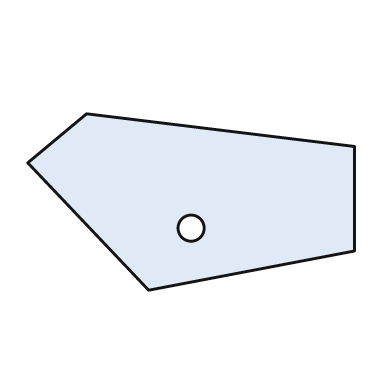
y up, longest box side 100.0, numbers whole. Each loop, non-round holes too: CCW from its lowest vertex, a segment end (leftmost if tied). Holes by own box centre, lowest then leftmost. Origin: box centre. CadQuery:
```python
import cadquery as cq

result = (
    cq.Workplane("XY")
    .moveTo(-13.0, -27.0)
    .lineTo(50.0, -15.0)
    .lineTo(50.0, 17.0)
    .lineTo(-32.0, 27.0)
    .lineTo(-50.0, 12.0)
    .close()
    .moveTo(0.0, -8.0)
    .circle(4.0)
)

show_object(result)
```